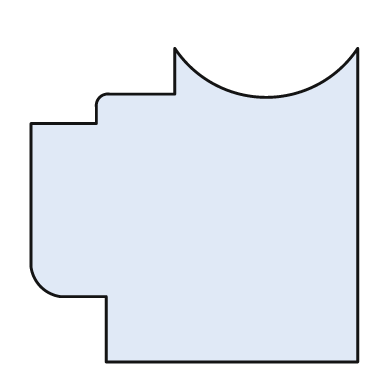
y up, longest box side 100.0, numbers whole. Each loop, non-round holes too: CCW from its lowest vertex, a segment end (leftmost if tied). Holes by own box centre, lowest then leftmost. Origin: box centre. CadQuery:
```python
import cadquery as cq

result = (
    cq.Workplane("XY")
    .moveTo(-27.0, -48.0)
    .lineTo(50.0, -48.0)
    .lineTo(50.0, 48.0)
    .threePointArc((22.0, 33.0), (-6.0, 48.0))
    .lineTo(-6.0, 34.0)
    .lineTo(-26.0, 34.0)
    .threePointArc((-29.0, 33.0), (-30.0, 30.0))
    .lineTo(-30.0, 25.0)
    .lineTo(-50.0, 25.0)
    .lineTo(-50.0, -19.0)
    .threePointArc((-47.0, -25.0), (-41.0, -28.0))
    .lineTo(-27.0, -28.0)
    .close()
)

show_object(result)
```